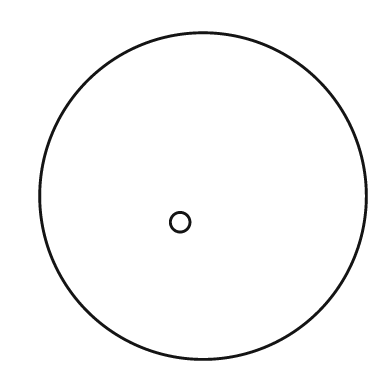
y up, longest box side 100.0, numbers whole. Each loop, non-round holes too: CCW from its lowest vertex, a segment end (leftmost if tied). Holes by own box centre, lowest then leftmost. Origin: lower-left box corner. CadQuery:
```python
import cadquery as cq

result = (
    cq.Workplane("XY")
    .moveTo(50.0, 50.0)
    .circle(50.0)
    .moveTo(43.0, 42.0)
    .circle(3.0)
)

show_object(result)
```